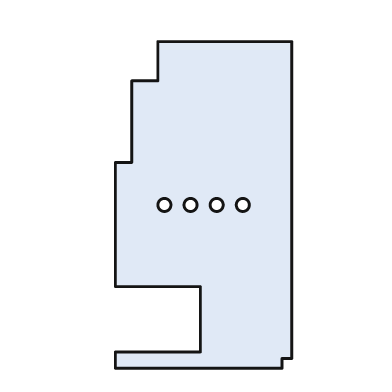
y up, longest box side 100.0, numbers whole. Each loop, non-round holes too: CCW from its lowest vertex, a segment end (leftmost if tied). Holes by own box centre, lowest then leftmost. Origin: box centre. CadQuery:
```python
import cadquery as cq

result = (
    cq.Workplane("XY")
    .moveTo(-27.0, -50.0)
    .lineTo(24.0, -50.0)
    .lineTo(24.0, -47.0)
    .lineTo(27.0, -47.0)
    .lineTo(27.0, 50.0)
    .lineTo(-14.0, 50.0)
    .lineTo(-14.0, 38.0)
    .lineTo(-22.0, 38.0)
    .lineTo(-22.0, 13.0)
    .lineTo(-27.0, 13.0)
    .lineTo(-27.0, -25.0)
    .lineTo(-1.0, -25.0)
    .lineTo(-1.0, -45.0)
    .lineTo(-27.0, -45.0)
    .close()
    .moveTo(-12.0, 0.0)
    .circle(2.0)
    .moveTo(-4.0, 0.0)
    .circle(2.0)
    .moveTo(4.0, 0.0)
    .circle(2.0)
    .moveTo(12.0, 0.0)
    .circle(2.0)
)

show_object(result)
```